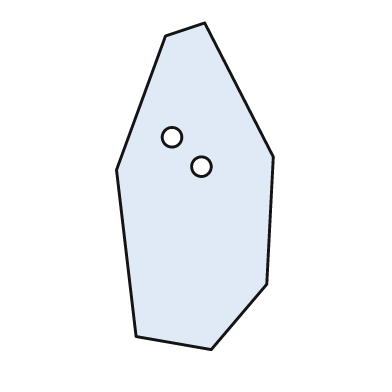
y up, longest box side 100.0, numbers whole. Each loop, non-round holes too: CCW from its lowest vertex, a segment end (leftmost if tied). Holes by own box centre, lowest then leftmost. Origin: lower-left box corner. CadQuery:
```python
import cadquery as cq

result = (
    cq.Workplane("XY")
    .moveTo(29.0, 0.0)
    .lineTo(46.0, 20.0)
    .lineTo(48.0, 59.0)
    .lineTo(27.0, 100.0)
    .lineTo(15.0, 96.0)
    .lineTo(0.0, 55.0)
    .lineTo(6.0, 4.0)
    .close()
    .moveTo(26.0, 56.0)
    .circle(3.0)
    .moveTo(17.0, 65.0)
    .circle(3.0)
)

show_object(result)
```